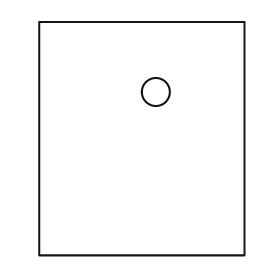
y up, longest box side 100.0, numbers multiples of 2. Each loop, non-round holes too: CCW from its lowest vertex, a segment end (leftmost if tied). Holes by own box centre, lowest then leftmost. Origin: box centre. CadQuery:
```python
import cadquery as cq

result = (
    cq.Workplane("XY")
    .moveTo(-44.0, -50.0)
    .lineTo(44.0, -50.0)
    .lineTo(44.0, 50.0)
    .lineTo(-44.0, 50.0)
    .close()
    .moveTo(6.0, 20.0)
    .circle(6.0)
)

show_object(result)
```